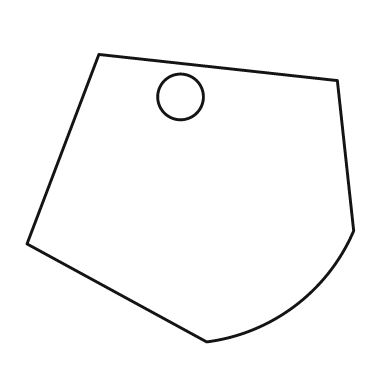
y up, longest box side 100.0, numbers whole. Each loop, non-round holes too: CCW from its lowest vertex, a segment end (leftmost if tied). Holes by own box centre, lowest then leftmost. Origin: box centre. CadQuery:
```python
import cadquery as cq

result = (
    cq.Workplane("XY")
    .moveTo(5.0, -44.0)
    .threePointArc((32.0, -33.0), (50.0, -10.0))
    .lineTo(45.0, 36.0)
    .lineTo(-28.0, 44.0)
    .lineTo(-50.0, -14.0)
    .close()
    .moveTo(-3.0, 31.0)
    .circle(7.0)
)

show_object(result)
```